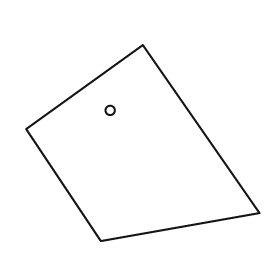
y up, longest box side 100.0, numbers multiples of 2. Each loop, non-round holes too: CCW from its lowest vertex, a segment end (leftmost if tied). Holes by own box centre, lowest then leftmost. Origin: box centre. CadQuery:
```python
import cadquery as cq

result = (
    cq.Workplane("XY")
    .moveTo(-18.0, -42.0)
    .lineTo(50.0, -30.0)
    .lineTo(0.0, 42.0)
    .lineTo(-50.0, 6.0)
    .close()
    .moveTo(-14.0, 14.0)
    .circle(2.0)
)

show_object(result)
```